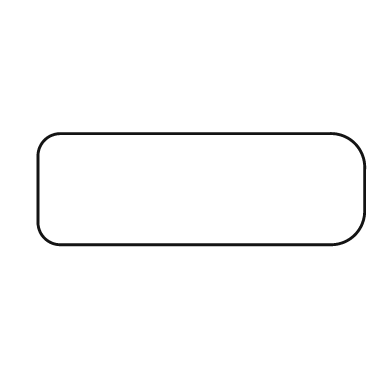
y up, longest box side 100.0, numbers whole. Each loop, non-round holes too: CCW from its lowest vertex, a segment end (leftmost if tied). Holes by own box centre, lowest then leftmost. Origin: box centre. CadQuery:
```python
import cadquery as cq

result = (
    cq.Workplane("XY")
    .moveTo(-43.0, -17.0)
    .lineTo(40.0, -17.0)
    .threePointArc((47.0, -14.0), (50.0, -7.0))
    .lineTo(50.0, 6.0)
    .threePointArc((47.0, 14.0), (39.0, 17.0))
    .lineTo(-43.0, 17.0)
    .threePointArc((-48.0, 15.0), (-50.0, 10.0))
    .lineTo(-50.0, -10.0)
    .threePointArc((-48.0, -15.0), (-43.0, -17.0))
    .close()
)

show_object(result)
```